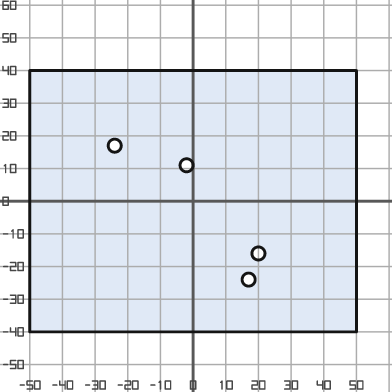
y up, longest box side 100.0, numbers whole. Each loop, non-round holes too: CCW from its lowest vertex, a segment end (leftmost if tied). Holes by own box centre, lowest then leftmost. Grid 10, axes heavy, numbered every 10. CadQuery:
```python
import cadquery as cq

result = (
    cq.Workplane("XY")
    .moveTo(-50.0, -40.0)
    .lineTo(50.0, -40.0)
    .lineTo(50.0, 40.0)
    .lineTo(-50.0, 40.0)
    .close()
    .moveTo(17.0, -24.0)
    .circle(2.0)
    .moveTo(20.0, -16.0)
    .circle(2.0)
    .moveTo(-2.0, 11.0)
    .circle(2.0)
    .moveTo(-24.0, 17.0)
    .circle(2.0)
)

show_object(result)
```